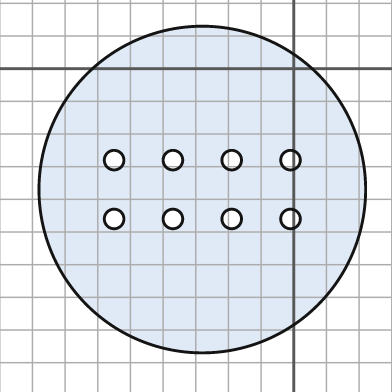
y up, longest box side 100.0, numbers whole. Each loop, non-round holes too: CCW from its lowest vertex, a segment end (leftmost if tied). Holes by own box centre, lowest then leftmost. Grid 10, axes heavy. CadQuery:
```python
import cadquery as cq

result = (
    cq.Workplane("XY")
    .moveTo(-28.0, -37.0)
    .circle(50.0)
    .moveTo(-55.0, -46.0)
    .circle(3.0)
    .moveTo(-37.0, -46.0)
    .circle(3.0)
    .moveTo(-19.0, -46.0)
    .circle(3.0)
    .moveTo(-1.0, -46.0)
    .circle(3.0)
    .moveTo(-55.0, -28.0)
    .circle(3.0)
    .moveTo(-37.0, -28.0)
    .circle(3.0)
    .moveTo(-19.0, -28.0)
    .circle(3.0)
    .moveTo(-1.0, -28.0)
    .circle(3.0)
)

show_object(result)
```